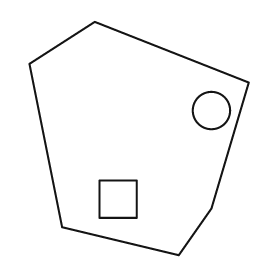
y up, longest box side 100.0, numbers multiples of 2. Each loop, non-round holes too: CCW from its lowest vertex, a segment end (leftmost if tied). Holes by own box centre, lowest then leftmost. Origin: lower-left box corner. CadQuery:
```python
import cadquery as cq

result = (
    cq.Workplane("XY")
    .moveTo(64.0, 0.0)
    .lineTo(78.0, 20.0)
    .lineTo(94.0, 74.0)
    .lineTo(28.0, 100.0)
    .lineTo(0.0, 82.0)
    .lineTo(14.0, 12.0)
    .close()
    .moveTo(30.0, 16.0)
    .lineTo(46.0, 16.0)
    .lineTo(46.0, 32.0)
    .lineTo(30.0, 32.0)
    .close()
    .moveTo(78.0, 62.0)
    .circle(8.0)
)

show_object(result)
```